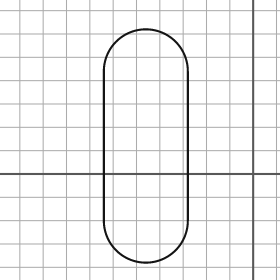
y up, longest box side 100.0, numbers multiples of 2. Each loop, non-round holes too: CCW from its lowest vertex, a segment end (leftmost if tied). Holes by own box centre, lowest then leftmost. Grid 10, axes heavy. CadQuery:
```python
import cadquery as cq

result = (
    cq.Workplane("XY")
    .moveTo(-64.0, -20.0)
    .threePointArc((-46.0, -38.0), (-28.0, -20.0))
    .lineTo(-28.0, 44.0)
    .threePointArc((-46.0, 62.0), (-64.0, 44.0))
    .close()
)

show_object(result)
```